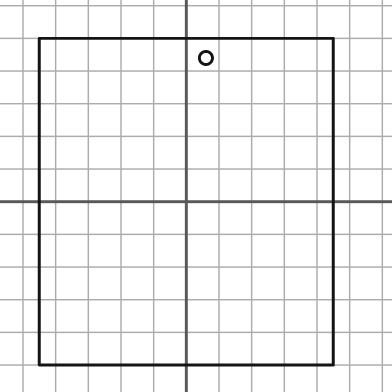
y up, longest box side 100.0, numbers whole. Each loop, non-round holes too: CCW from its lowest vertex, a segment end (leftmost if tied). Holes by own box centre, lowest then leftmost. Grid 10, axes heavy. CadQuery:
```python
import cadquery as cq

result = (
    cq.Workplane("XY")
    .moveTo(-45.0, -50.0)
    .lineTo(45.0, -50.0)
    .lineTo(45.0, 50.0)
    .lineTo(-45.0, 50.0)
    .close()
    .moveTo(6.0, 44.0)
    .circle(2.0)
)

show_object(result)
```